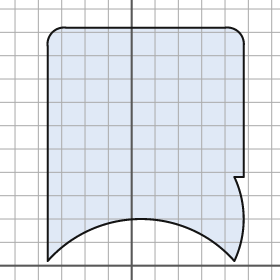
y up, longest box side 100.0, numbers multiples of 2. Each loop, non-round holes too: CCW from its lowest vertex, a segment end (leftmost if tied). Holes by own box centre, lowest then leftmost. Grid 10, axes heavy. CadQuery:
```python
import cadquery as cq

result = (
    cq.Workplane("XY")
    .moveTo(-36.0, 2.0)
    .threePointArc((4.0, 20.0), (44.0, 2.0))
    .threePointArc((48.0, 20.0), (44.0, 38.0))
    .lineTo(48.0, 38.0)
    .lineTo(48.0, 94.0)
    .threePointArc((46.0, 100.0), (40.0, 102.0))
    .lineTo(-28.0, 102.0)
    .threePointArc((-34.0, 100.0), (-36.0, 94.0))
    .close()
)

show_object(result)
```